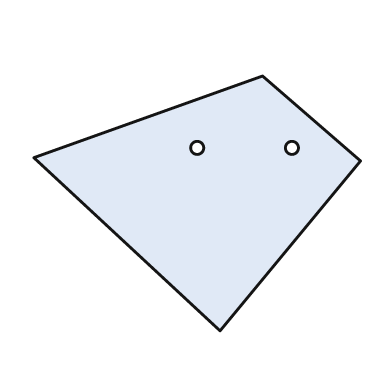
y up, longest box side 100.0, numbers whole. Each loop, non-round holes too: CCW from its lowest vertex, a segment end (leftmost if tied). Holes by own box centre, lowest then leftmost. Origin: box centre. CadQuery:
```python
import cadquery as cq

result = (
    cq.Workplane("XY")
    .moveTo(7.0, -39.0)
    .lineTo(50.0, 13.0)
    .lineTo(20.0, 39.0)
    .lineTo(-50.0, 14.0)
    .close()
    .moveTo(0.0, 17.0)
    .circle(2.0)
    .moveTo(29.0, 17.0)
    .circle(2.0)
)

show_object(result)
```